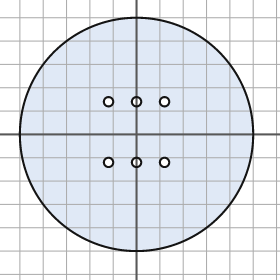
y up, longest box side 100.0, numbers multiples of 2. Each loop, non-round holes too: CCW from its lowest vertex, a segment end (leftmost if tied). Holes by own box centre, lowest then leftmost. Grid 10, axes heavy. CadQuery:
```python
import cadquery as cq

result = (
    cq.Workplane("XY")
    .moveTo(0.0, 0.0)
    .circle(50.0)
    .moveTo(-12.0, -12.0)
    .circle(2.0)
    .moveTo(0.0, -12.0)
    .circle(2.0)
    .moveTo(12.0, -12.0)
    .circle(2.0)
    .moveTo(-12.0, 14.0)
    .circle(2.0)
    .moveTo(0.0, 14.0)
    .circle(2.0)
    .moveTo(12.0, 14.0)
    .circle(2.0)
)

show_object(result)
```